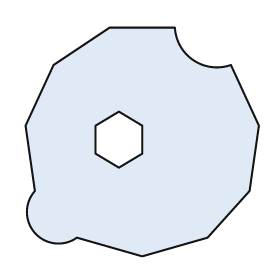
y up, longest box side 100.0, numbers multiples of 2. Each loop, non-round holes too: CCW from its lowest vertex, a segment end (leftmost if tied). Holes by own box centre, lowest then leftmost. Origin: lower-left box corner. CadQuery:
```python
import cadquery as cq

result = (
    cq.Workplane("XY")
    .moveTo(50.0, 0.0)
    .lineTo(78.0, 8.0)
    .lineTo(96.0, 28.0)
    .lineTo(100.0, 56.0)
    .lineTo(88.0, 82.0)
    .threePointArc((72.0, 84.0), (64.0, 98.0))
    .lineTo(36.0, 98.0)
    .lineTo(12.0, 82.0)
    .lineTo(0.0, 56.0)
    .lineTo(4.0, 28.0)
    .threePointArc((4.0, 10.0), (22.0, 8.0))
    .close()
    .moveTo(40.0, 38.0)
    .lineTo(50.0, 44.0)
    .lineTo(50.0, 56.0)
    .lineTo(40.0, 62.0)
    .lineTo(30.0, 56.0)
    .lineTo(30.0, 44.0)
    .close()
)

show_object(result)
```